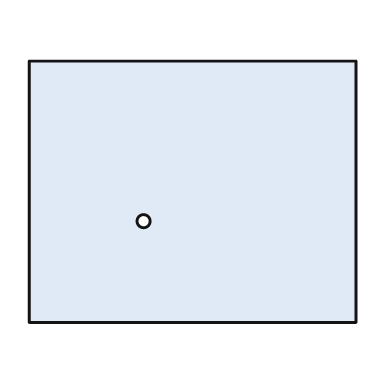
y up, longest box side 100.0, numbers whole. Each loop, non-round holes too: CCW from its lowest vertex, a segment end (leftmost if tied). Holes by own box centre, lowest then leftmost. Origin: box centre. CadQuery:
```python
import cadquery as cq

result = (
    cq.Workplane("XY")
    .moveTo(-50.0, -40.0)
    .lineTo(50.0, -40.0)
    .lineTo(50.0, 40.0)
    .lineTo(-50.0, 40.0)
    .close()
    .moveTo(-15.0, -9.0)
    .circle(2.0)
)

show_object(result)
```